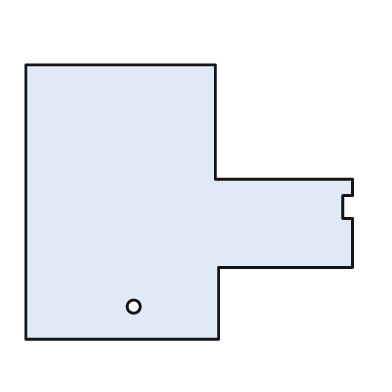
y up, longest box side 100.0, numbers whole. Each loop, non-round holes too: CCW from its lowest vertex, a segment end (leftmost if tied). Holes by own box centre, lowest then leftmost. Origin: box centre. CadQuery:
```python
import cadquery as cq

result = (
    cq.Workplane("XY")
    .moveTo(-50.0, -42.0)
    .lineTo(9.0, -42.0)
    .lineTo(9.0, -20.0)
    .lineTo(50.0, -20.0)
    .lineTo(50.0, -5.0)
    .lineTo(47.0, -5.0)
    .lineTo(47.0, 2.0)
    .lineTo(50.0, 2.0)
    .lineTo(50.0, 7.0)
    .lineTo(8.0, 7.0)
    .lineTo(8.0, 42.0)
    .lineTo(-50.0, 42.0)
    .close()
    .moveTo(-17.0, -32.0)
    .circle(2.0)
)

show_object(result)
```